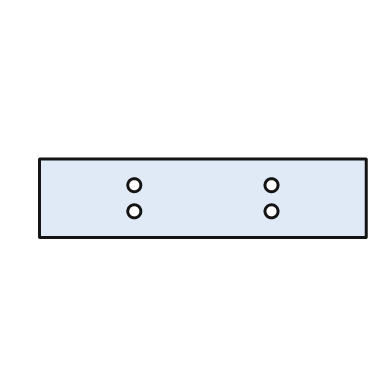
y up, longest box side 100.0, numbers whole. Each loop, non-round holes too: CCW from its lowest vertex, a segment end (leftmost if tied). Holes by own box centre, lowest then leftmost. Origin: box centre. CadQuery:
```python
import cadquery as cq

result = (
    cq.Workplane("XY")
    .moveTo(-50.0, -12.0)
    .lineTo(50.0, -12.0)
    .lineTo(50.0, 12.0)
    .lineTo(-50.0, 12.0)
    .close()
    .moveTo(-21.0, -4.0)
    .circle(2.0)
    .moveTo(21.0, -4.0)
    .circle(2.0)
    .moveTo(-21.0, 4.0)
    .circle(2.0)
    .moveTo(21.0, 4.0)
    .circle(2.0)
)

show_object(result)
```